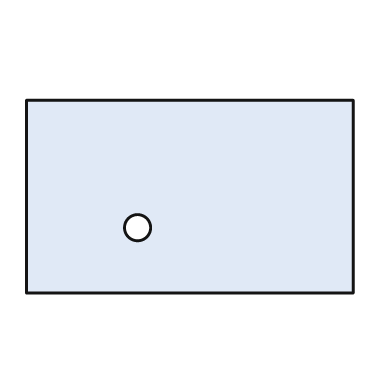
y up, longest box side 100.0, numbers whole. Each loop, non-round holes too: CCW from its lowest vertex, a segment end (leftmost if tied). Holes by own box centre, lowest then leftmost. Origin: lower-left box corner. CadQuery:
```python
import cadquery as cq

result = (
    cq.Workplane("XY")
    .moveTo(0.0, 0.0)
    .lineTo(100.0, 0.0)
    .lineTo(100.0, 59.0)
    .lineTo(0.0, 59.0)
    .close()
    .moveTo(34.0, 20.0)
    .circle(4.0)
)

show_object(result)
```